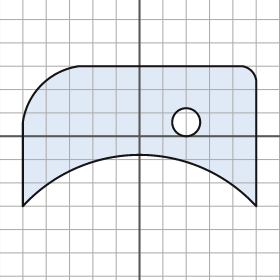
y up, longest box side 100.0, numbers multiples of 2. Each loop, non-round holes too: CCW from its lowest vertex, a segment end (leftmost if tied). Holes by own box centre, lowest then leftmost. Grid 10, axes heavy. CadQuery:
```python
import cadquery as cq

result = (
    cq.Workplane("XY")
    .moveTo(-50.0, -30.0)
    .threePointArc((0.0, -8.0), (50.0, -30.0))
    .lineTo(50.0, 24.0)
    .threePointArc((48.0, 28.0), (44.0, 30.0))
    .lineTo(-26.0, 30.0)
    .threePointArc((-42.0, 22.0), (-50.0, 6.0))
    .close()
    .moveTo(20.0, 6.0)
    .circle(6.0)
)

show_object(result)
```